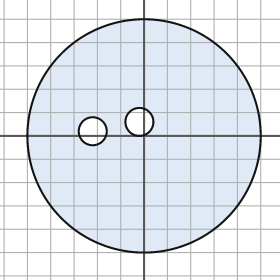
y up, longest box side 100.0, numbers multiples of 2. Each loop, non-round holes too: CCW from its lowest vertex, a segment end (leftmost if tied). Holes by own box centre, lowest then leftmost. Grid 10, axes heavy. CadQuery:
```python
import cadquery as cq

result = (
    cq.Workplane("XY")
    .moveTo(0.0, 0.0)
    .circle(50.0)
    .moveTo(-22.0, 2.0)
    .circle(6.0)
    .moveTo(-2.0, 6.0)
    .circle(6.0)
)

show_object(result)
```